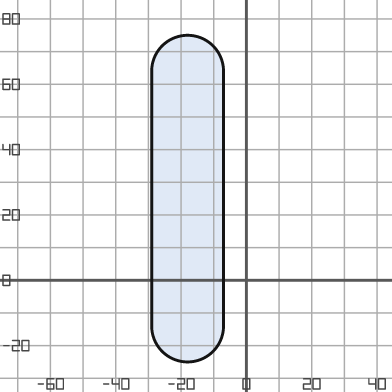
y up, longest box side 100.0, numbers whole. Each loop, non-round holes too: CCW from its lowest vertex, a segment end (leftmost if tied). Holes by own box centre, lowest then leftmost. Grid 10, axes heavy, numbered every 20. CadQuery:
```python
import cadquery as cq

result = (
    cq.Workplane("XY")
    .moveTo(-29.0, -14.0)
    .threePointArc((-18.0, -25.0), (-7.0, -14.0))
    .lineTo(-7.0, 64.0)
    .threePointArc((-18.0, 75.0), (-29.0, 64.0))
    .close()
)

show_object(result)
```